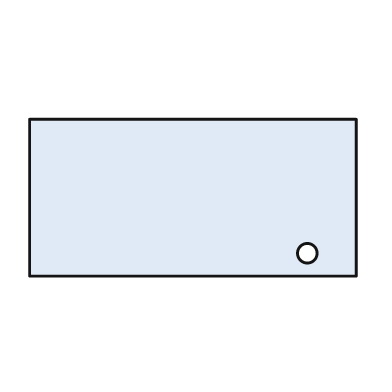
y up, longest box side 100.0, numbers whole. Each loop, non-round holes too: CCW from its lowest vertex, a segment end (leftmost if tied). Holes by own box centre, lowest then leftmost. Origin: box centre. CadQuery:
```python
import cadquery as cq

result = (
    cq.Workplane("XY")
    .moveTo(-50.0, -24.0)
    .lineTo(50.0, -24.0)
    .lineTo(50.0, 24.0)
    .lineTo(-50.0, 24.0)
    .close()
    .moveTo(35.0, -17.0)
    .circle(3.0)
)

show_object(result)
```